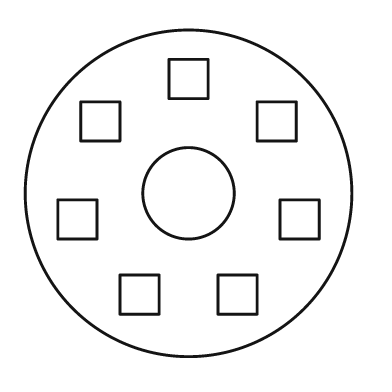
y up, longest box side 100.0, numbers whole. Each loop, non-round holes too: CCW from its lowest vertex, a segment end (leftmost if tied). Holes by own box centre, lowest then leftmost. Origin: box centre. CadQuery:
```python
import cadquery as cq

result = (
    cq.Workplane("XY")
    .moveTo(0.0, 0.0)
    .circle(50.0)
    .moveTo(-21.0, -37.0)
    .lineTo(-9.0, -37.0)
    .lineTo(-9.0, -25.0)
    .lineTo(-21.0, -25.0)
    .close()
    .moveTo(9.0, -37.0)
    .lineTo(21.0, -37.0)
    .lineTo(21.0, -25.0)
    .lineTo(9.0, -25.0)
    .close()
    .moveTo(-40.0, -14.0)
    .lineTo(-28.0, -14.0)
    .lineTo(-28.0, -2.0)
    .lineTo(-40.0, -2.0)
    .close()
    .moveTo(28.0, -14.0)
    .lineTo(40.0, -14.0)
    .lineTo(40.0, -2.0)
    .lineTo(28.0, -2.0)
    .close()
    .moveTo(0.0, 0.0)
    .circle(14.0)
    .moveTo(-33.0, 16.0)
    .lineTo(-21.0, 16.0)
    .lineTo(-21.0, 28.0)
    .lineTo(-33.0, 28.0)
    .close()
    .moveTo(21.0, 16.0)
    .lineTo(33.0, 16.0)
    .lineTo(33.0, 28.0)
    .lineTo(21.0, 28.0)
    .close()
    .moveTo(-6.0, 29.0)
    .lineTo(6.0, 29.0)
    .lineTo(6.0, 41.0)
    .lineTo(-6.0, 41.0)
    .close()
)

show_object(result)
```